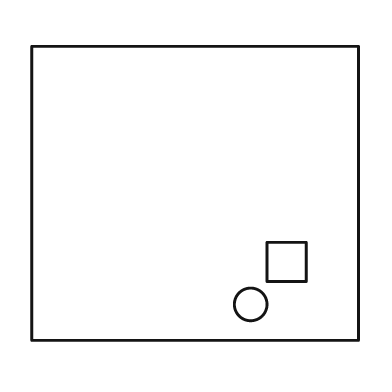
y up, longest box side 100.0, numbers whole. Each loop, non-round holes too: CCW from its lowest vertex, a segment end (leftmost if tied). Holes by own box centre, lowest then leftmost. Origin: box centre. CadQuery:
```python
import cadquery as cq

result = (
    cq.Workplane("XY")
    .moveTo(-50.0, -45.0)
    .lineTo(50.0, -45.0)
    .lineTo(50.0, 45.0)
    .lineTo(-50.0, 45.0)
    .close()
    .moveTo(17.0, -34.0)
    .circle(5.0)
    .moveTo(22.0, -27.0)
    .lineTo(34.0, -27.0)
    .lineTo(34.0, -15.0)
    .lineTo(22.0, -15.0)
    .close()
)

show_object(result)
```